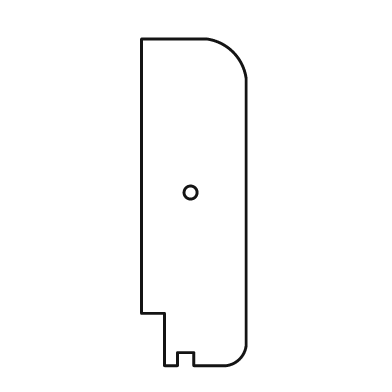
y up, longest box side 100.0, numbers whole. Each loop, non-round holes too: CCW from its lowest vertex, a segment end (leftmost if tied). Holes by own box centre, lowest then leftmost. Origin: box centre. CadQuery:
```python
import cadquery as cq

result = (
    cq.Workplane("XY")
    .moveTo(-9.0, -50.0)
    .lineTo(-5.0, -50.0)
    .lineTo(-5.0, -46.0)
    .lineTo(0.0, -46.0)
    .lineTo(0.0, -50.0)
    .lineTo(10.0, -50.0)
    .threePointArc((14.0, -48.0), (16.0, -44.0))
    .lineTo(16.0, 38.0)
    .threePointArc((12.0, 46.0), (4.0, 50.0))
    .lineTo(-16.0, 50.0)
    .lineTo(-16.0, -34.0)
    .lineTo(-9.0, -34.0)
    .close()
    .moveTo(-1.0, 3.0)
    .circle(2.0)
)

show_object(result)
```